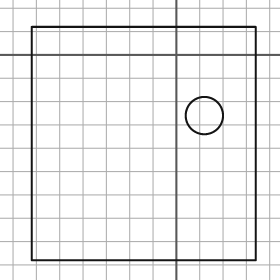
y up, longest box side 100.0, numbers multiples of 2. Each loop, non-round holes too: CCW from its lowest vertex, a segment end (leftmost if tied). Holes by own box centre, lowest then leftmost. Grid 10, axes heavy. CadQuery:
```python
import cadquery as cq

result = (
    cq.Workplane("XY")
    .moveTo(-62.0, -88.0)
    .lineTo(34.0, -88.0)
    .lineTo(34.0, 12.0)
    .lineTo(-62.0, 12.0)
    .close()
    .moveTo(12.0, -26.0)
    .circle(8.0)
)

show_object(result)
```